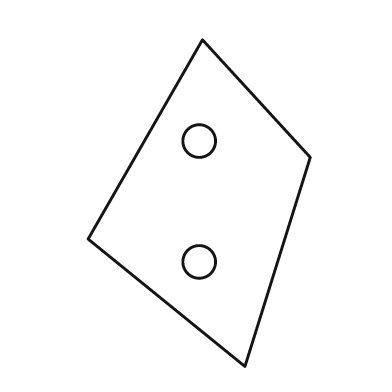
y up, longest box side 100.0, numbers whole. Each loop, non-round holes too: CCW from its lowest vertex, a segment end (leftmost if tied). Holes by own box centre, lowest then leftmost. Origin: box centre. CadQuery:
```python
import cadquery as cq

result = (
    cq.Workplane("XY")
    .moveTo(14.0, -50.0)
    .lineTo(34.0, 14.0)
    .lineTo(1.0, 50.0)
    .lineTo(-34.0, -11.0)
    .close()
    .moveTo(0.0, -18.0)
    .circle(5.0)
    .moveTo(0.0, 19.0)
    .circle(5.0)
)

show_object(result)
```